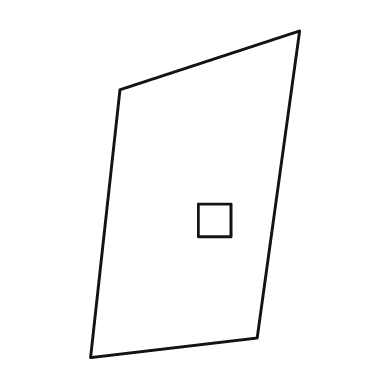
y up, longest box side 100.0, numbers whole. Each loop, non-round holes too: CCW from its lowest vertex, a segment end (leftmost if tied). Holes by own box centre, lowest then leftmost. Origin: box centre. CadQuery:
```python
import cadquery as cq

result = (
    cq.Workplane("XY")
    .moveTo(-32.0, -50.0)
    .lineTo(19.0, -44.0)
    .lineTo(32.0, 50.0)
    .lineTo(-23.0, 32.0)
    .close()
    .moveTo(1.0, -13.0)
    .lineTo(11.0, -13.0)
    .lineTo(11.0, -3.0)
    .lineTo(1.0, -3.0)
    .close()
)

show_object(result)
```